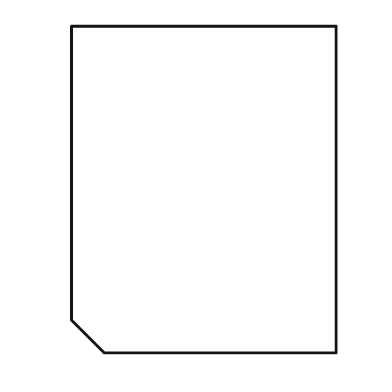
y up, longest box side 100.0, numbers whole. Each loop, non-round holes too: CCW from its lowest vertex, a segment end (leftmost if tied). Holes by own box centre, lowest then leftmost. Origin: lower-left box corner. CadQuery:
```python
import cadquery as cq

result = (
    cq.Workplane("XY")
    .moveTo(10.0, 0.0)
    .lineTo(81.0, 0.0)
    .lineTo(81.0, 100.0)
    .lineTo(0.0, 100.0)
    .lineTo(0.0, 10.0)
    .close()
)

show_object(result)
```